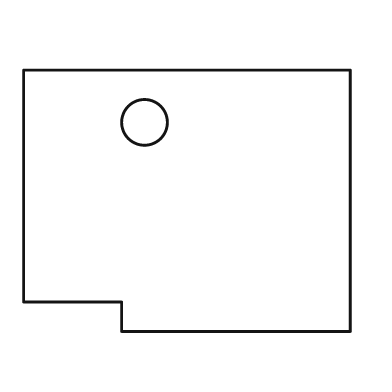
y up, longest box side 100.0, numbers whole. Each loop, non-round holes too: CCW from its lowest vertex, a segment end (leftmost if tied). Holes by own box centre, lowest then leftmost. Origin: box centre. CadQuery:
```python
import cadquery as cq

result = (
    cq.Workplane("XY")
    .moveTo(-20.0, -40.0)
    .lineTo(50.0, -40.0)
    .lineTo(50.0, 40.0)
    .lineTo(-50.0, 40.0)
    .lineTo(-50.0, -31.0)
    .lineTo(-20.0, -31.0)
    .close()
    .moveTo(-13.0, 24.0)
    .circle(7.0)
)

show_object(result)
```